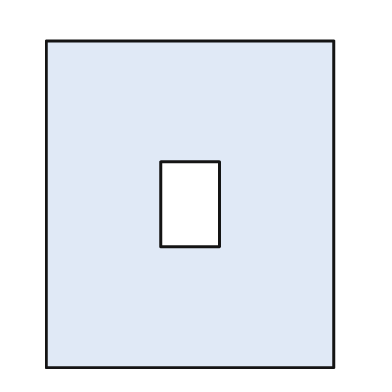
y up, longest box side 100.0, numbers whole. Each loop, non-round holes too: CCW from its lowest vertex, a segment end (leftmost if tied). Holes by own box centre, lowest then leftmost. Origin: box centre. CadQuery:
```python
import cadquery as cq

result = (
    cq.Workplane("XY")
    .moveTo(-44.0, -50.0)
    .lineTo(44.0, -50.0)
    .lineTo(44.0, 50.0)
    .lineTo(-44.0, 50.0)
    .close()
    .moveTo(-9.0, -13.0)
    .lineTo(9.0, -13.0)
    .lineTo(9.0, 13.0)
    .lineTo(-9.0, 13.0)
    .close()
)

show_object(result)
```